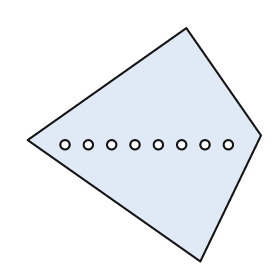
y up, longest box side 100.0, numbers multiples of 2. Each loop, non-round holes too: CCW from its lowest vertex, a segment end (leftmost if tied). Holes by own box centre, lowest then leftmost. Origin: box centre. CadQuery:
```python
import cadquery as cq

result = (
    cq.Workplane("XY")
    .moveTo(24.0, -50.0)
    .lineTo(50.0, 4.0)
    .lineTo(18.0, 50.0)
    .lineTo(-50.0, 2.0)
    .close()
    .moveTo(-34.0, 0.0)
    .circle(2.0)
    .moveTo(-24.0, 0.0)
    .circle(2.0)
    .moveTo(-14.0, 0.0)
    .circle(2.0)
    .moveTo(-4.0, 0.0)
    .circle(2.0)
    .moveTo(6.0, 0.0)
    .circle(2.0)
    .moveTo(16.0, 0.0)
    .circle(2.0)
    .moveTo(26.0, 0.0)
    .circle(2.0)
    .moveTo(36.0, 0.0)
    .circle(2.0)
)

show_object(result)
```